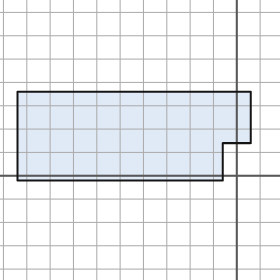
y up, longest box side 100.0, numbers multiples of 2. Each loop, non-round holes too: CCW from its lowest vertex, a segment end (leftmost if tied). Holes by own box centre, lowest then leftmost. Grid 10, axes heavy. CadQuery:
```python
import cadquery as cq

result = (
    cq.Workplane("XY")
    .moveTo(-94.0, -2.0)
    .lineTo(-6.0, -2.0)
    .lineTo(-6.0, 14.0)
    .lineTo(6.0, 14.0)
    .lineTo(6.0, 36.0)
    .lineTo(-94.0, 36.0)
    .close()
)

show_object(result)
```